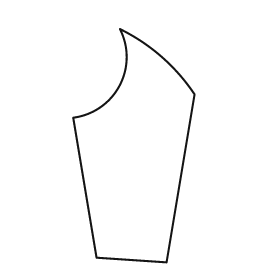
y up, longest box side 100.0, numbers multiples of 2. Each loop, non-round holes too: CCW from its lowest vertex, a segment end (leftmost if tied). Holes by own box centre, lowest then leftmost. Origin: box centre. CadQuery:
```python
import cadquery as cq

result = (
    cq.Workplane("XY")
    .moveTo(14.0, -50.0)
    .lineTo(26.0, 22.0)
    .threePointArc((12.0, 38.0), (-6.0, 50.0))
    .threePointArc((-6.0, 26.0), (-26.0, 12.0))
    .lineTo(-16.0, -48.0)
    .close()
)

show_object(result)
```